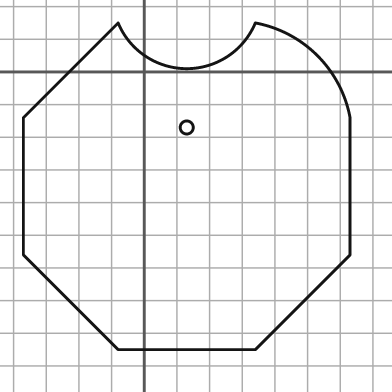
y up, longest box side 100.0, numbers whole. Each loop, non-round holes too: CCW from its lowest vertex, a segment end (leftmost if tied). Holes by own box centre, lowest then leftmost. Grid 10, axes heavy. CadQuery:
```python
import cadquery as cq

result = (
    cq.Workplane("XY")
    .moveTo(-8.0, -85.0)
    .lineTo(34.0, -85.0)
    .lineTo(63.0, -56.0)
    .lineTo(63.0, -14.0)
    .threePointArc((53.0, 5.0), (34.0, 15.0))
    .threePointArc((13.0, 1.0), (-8.0, 15.0))
    .lineTo(-37.0, -14.0)
    .lineTo(-37.0, -56.0)
    .close()
    .moveTo(13.0, -17.0)
    .circle(2.0)
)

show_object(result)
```